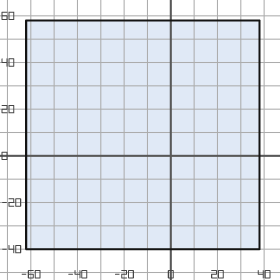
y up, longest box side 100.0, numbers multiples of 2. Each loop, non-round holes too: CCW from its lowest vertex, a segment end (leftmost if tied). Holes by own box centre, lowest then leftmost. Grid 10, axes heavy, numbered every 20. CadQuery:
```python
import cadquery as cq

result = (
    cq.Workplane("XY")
    .moveTo(-62.0, -40.0)
    .lineTo(38.0, -40.0)
    .lineTo(38.0, 58.0)
    .lineTo(-62.0, 58.0)
    .close()
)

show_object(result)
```